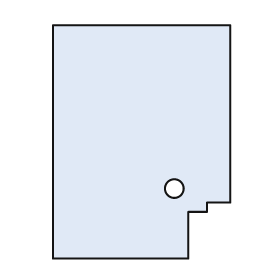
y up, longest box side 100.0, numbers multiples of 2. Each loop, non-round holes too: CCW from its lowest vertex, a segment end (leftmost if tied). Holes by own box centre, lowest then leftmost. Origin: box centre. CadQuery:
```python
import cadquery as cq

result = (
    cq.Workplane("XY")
    .moveTo(-38.0, -50.0)
    .lineTo(20.0, -50.0)
    .lineTo(20.0, -30.0)
    .lineTo(28.0, -30.0)
    .lineTo(28.0, -26.0)
    .lineTo(38.0, -26.0)
    .lineTo(38.0, 50.0)
    .lineTo(-38.0, 50.0)
    .close()
    .moveTo(14.0, -20.0)
    .circle(4.0)
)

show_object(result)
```